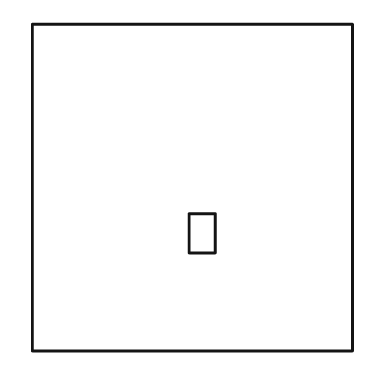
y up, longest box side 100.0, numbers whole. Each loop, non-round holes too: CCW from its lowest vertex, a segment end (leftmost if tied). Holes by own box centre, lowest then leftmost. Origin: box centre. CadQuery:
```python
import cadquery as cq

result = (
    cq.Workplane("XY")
    .moveTo(-49.0, -50.0)
    .lineTo(49.0, -50.0)
    .lineTo(49.0, 50.0)
    .lineTo(-49.0, 50.0)
    .close()
    .moveTo(-1.0, -20.0)
    .lineTo(7.0, -20.0)
    .lineTo(7.0, -8.0)
    .lineTo(-1.0, -8.0)
    .close()
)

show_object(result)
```